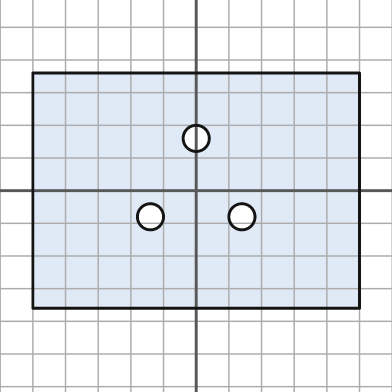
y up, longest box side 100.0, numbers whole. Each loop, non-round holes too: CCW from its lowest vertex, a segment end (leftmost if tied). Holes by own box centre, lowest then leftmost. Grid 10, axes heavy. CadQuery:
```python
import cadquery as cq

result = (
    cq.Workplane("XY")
    .moveTo(-50.0, -36.0)
    .lineTo(50.0, -36.0)
    .lineTo(50.0, 36.0)
    .lineTo(-50.0, 36.0)
    .close()
    .moveTo(-14.0, -8.0)
    .circle(4.0)
    .moveTo(14.0, -8.0)
    .circle(4.0)
    .moveTo(0.0, 16.0)
    .circle(4.0)
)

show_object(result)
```